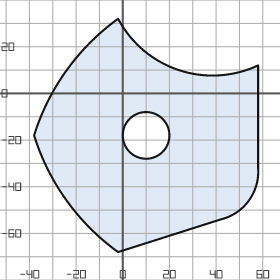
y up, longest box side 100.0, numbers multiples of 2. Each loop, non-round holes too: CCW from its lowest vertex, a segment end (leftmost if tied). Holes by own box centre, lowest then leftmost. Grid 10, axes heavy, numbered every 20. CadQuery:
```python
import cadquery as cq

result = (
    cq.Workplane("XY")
    .moveTo(-2.0, -68.0)
    .lineTo(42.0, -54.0)
    .threePointArc((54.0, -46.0), (58.0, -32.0))
    .lineTo(58.0, 12.0)
    .threePointArc((24.0, 10.0), (-2.0, 32.0))
    .threePointArc((-24.0, 10.0), (-38.0, -18.0))
    .threePointArc((-24.0, -46.0), (-2.0, -68.0))
    .close()
    .moveTo(10.0, -18.0)
    .circle(10.0)
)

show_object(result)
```